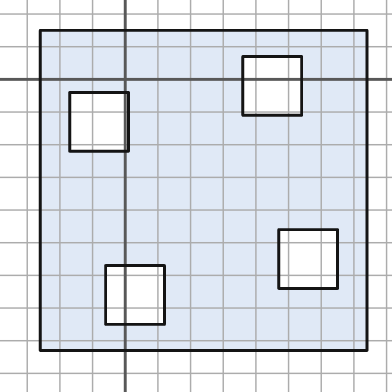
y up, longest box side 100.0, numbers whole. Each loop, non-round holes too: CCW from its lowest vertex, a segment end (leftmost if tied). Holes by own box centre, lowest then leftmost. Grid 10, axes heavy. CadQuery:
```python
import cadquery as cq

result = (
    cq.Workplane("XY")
    .moveTo(-26.0, -83.0)
    .lineTo(74.0, -83.0)
    .lineTo(74.0, 15.0)
    .lineTo(-26.0, 15.0)
    .close()
    .moveTo(-6.0, -75.0)
    .lineTo(12.0, -75.0)
    .lineTo(12.0, -57.0)
    .lineTo(-6.0, -57.0)
    .close()
    .moveTo(47.0, -64.0)
    .lineTo(65.0, -64.0)
    .lineTo(65.0, -46.0)
    .lineTo(47.0, -46.0)
    .close()
    .moveTo(-17.0, -22.0)
    .lineTo(1.0, -22.0)
    .lineTo(1.0, -4.0)
    .lineTo(-17.0, -4.0)
    .close()
    .moveTo(36.0, -11.0)
    .lineTo(54.0, -11.0)
    .lineTo(54.0, 7.0)
    .lineTo(36.0, 7.0)
    .close()
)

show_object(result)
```